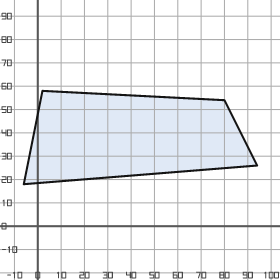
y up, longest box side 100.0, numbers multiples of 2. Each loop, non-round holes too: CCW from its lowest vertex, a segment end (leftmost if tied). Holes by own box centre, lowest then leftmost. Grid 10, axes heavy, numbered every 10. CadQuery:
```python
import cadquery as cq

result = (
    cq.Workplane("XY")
    .moveTo(-6.0, 18.0)
    .lineTo(94.0, 26.0)
    .lineTo(80.0, 54.0)
    .lineTo(2.0, 58.0)
    .close()
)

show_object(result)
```